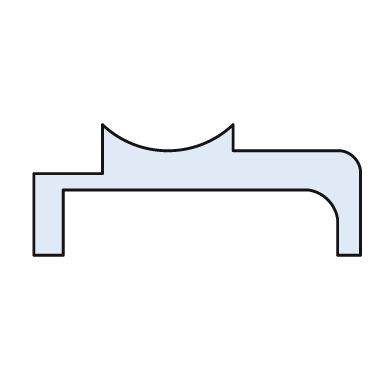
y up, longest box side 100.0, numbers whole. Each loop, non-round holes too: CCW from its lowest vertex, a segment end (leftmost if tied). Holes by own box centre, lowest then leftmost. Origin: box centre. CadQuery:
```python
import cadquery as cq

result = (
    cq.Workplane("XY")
    .moveTo(-50.0, -20.0)
    .lineTo(-41.0, -20.0)
    .lineTo(-41.0, 0.0)
    .lineTo(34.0, 0.0)
    .threePointArc((40.0, -3.0), (43.0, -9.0))
    .lineTo(43.0, -20.0)
    .lineTo(50.0, -20.0)
    .lineTo(50.0, 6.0)
    .threePointArc((48.0, 10.0), (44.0, 12.0))
    .lineTo(11.0, 12.0)
    .lineTo(11.0, 20.0)
    .threePointArc((-9.0, 12.0), (-29.0, 20.0))
    .lineTo(-29.0, 5.0)
    .lineTo(-50.0, 5.0)
    .close()
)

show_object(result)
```